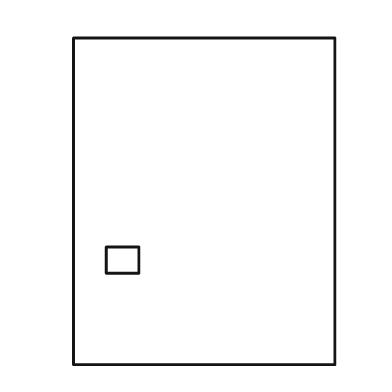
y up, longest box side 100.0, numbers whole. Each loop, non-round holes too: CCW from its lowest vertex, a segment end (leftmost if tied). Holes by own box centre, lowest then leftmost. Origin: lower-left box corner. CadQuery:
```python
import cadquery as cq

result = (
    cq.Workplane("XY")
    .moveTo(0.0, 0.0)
    .lineTo(80.0, 0.0)
    .lineTo(80.0, 100.0)
    .lineTo(0.0, 100.0)
    .close()
    .moveTo(10.0, 28.0)
    .lineTo(20.0, 28.0)
    .lineTo(20.0, 36.0)
    .lineTo(10.0, 36.0)
    .close()
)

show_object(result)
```